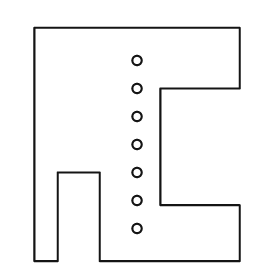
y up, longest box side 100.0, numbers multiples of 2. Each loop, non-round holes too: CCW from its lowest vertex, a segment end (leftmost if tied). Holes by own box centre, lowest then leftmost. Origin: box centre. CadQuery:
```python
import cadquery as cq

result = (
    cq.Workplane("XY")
    .moveTo(-44.0, -50.0)
    .lineTo(-34.0, -50.0)
    .lineTo(-34.0, -12.0)
    .lineTo(-16.0, -12.0)
    .lineTo(-16.0, -50.0)
    .lineTo(44.0, -50.0)
    .lineTo(44.0, -26.0)
    .lineTo(10.0, -26.0)
    .lineTo(10.0, 24.0)
    .lineTo(44.0, 24.0)
    .lineTo(44.0, 50.0)
    .lineTo(-44.0, 50.0)
    .close()
    .moveTo(0.0, -36.0)
    .circle(2.0)
    .moveTo(0.0, -24.0)
    .circle(2.0)
    .moveTo(0.0, -12.0)
    .circle(2.0)
    .moveTo(0.0, 0.0)
    .circle(2.0)
    .moveTo(0.0, 12.0)
    .circle(2.0)
    .moveTo(0.0, 24.0)
    .circle(2.0)
    .moveTo(0.0, 36.0)
    .circle(2.0)
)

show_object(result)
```